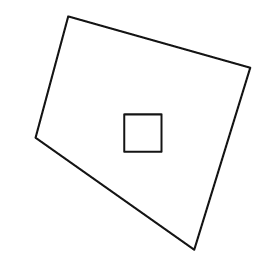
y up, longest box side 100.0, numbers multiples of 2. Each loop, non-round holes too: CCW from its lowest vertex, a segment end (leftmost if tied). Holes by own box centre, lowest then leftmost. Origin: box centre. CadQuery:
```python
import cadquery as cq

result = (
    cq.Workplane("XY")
    .moveTo(22.0, -50.0)
    .lineTo(46.0, 28.0)
    .lineTo(-32.0, 50.0)
    .lineTo(-46.0, -2.0)
    .close()
    .moveTo(-8.0, -8.0)
    .lineTo(8.0, -8.0)
    .lineTo(8.0, 8.0)
    .lineTo(-8.0, 8.0)
    .close()
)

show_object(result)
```